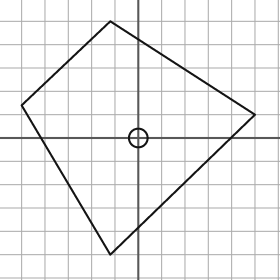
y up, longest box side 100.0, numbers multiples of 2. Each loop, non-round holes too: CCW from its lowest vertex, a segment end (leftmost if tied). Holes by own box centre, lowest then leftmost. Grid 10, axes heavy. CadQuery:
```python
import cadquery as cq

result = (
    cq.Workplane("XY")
    .moveTo(-12.0, -50.0)
    .lineTo(50.0, 10.0)
    .lineTo(-12.0, 50.0)
    .lineTo(-50.0, 14.0)
    .close()
    .moveTo(0.0, 0.0)
    .circle(4.0)
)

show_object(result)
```